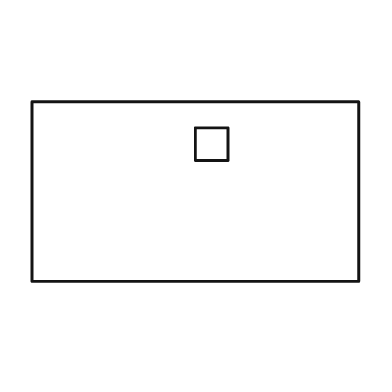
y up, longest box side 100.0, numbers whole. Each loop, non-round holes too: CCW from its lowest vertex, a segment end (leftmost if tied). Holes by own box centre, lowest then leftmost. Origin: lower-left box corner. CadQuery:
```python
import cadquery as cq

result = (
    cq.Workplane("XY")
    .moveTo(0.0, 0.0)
    .lineTo(100.0, 0.0)
    .lineTo(100.0, 55.0)
    .lineTo(0.0, 55.0)
    .close()
    .moveTo(50.0, 37.0)
    .lineTo(60.0, 37.0)
    .lineTo(60.0, 47.0)
    .lineTo(50.0, 47.0)
    .close()
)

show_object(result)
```